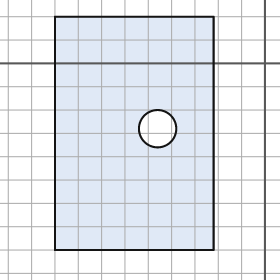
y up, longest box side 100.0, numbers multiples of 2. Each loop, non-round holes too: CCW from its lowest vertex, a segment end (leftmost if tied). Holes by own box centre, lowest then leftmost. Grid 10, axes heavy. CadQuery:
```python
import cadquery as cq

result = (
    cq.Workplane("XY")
    .moveTo(-90.0, -80.0)
    .lineTo(-22.0, -80.0)
    .lineTo(-22.0, 20.0)
    .lineTo(-90.0, 20.0)
    .close()
    .moveTo(-46.0, -28.0)
    .circle(8.0)
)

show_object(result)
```